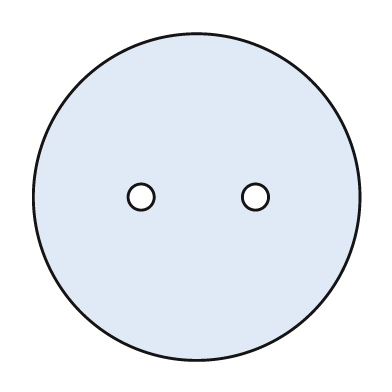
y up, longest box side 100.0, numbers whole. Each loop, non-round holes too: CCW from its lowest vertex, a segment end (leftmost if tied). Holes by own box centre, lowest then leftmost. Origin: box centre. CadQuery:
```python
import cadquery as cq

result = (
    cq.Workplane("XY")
    .moveTo(0.0, 0.0)
    .circle(50.0)
    .moveTo(-17.0, 0.0)
    .circle(4.0)
    .moveTo(18.0, 0.0)
    .circle(4.0)
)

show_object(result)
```